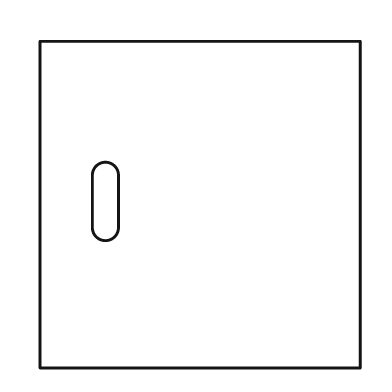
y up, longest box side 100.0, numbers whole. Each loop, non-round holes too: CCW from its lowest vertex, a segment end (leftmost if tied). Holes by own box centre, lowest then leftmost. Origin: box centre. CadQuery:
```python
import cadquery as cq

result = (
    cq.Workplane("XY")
    .moveTo(-49.0, -50.0)
    .lineTo(49.0, -50.0)
    .lineTo(49.0, 50.0)
    .lineTo(-49.0, 50.0)
    .close()
    .moveTo(-33.0, -7.0)
    .threePointArc((-29.0, -11.0), (-25.0, -7.0))
    .lineTo(-25.0, 9.0)
    .threePointArc((-29.0, 13.0), (-33.0, 9.0))
    .close()
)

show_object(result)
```